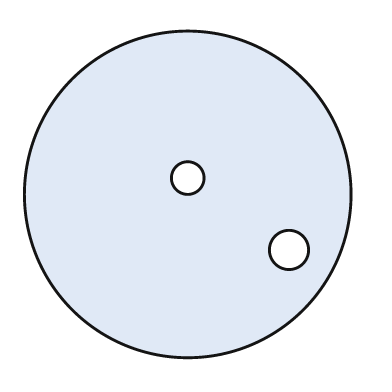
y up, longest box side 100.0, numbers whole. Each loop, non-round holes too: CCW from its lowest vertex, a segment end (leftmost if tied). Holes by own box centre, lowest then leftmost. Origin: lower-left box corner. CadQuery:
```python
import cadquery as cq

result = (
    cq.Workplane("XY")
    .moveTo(50.0, 50.0)
    .circle(50.0)
    .moveTo(81.0, 33.0)
    .circle(6.0)
    .moveTo(50.0, 55.0)
    .circle(5.0)
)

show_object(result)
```